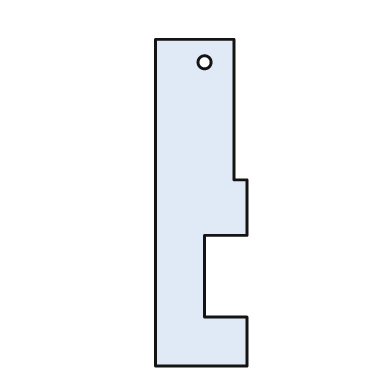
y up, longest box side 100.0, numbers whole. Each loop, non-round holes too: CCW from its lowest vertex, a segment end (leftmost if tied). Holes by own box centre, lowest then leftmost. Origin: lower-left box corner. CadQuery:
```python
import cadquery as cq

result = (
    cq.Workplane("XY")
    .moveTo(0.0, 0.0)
    .lineTo(28.0, 0.0)
    .lineTo(28.0, 15.0)
    .lineTo(15.0, 15.0)
    .lineTo(15.0, 40.0)
    .lineTo(28.0, 40.0)
    .lineTo(28.0, 57.0)
    .lineTo(24.0, 57.0)
    .lineTo(24.0, 100.0)
    .lineTo(0.0, 100.0)
    .close()
    .moveTo(15.0, 93.0)
    .circle(2.0)
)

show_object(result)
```